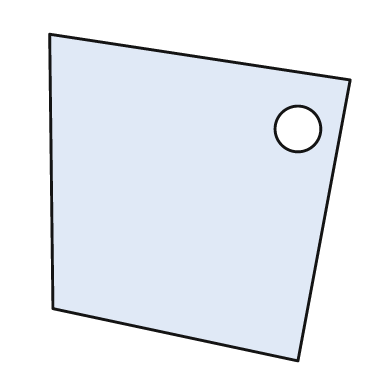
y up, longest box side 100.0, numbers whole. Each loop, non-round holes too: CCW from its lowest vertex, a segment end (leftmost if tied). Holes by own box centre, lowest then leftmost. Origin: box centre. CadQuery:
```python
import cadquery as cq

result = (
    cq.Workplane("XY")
    .moveTo(30.0, -50.0)
    .lineTo(46.0, 36.0)
    .lineTo(-46.0, 50.0)
    .lineTo(-45.0, -34.0)
    .close()
    .moveTo(30.0, 21.0)
    .circle(7.0)
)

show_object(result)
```